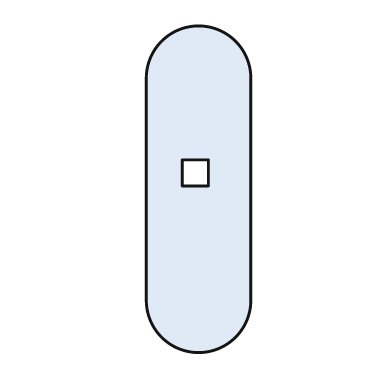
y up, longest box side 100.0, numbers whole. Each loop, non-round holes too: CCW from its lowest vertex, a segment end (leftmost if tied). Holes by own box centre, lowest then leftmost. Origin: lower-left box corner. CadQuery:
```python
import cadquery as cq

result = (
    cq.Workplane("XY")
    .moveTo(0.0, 16.0)
    .threePointArc((16.0, 0.0), (32.0, 16.0))
    .lineTo(32.0, 84.0)
    .threePointArc((16.0, 100.0), (0.0, 84.0))
    .close()
    .moveTo(11.0, 51.0)
    .lineTo(19.0, 51.0)
    .lineTo(19.0, 59.0)
    .lineTo(11.0, 59.0)
    .close()
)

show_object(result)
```